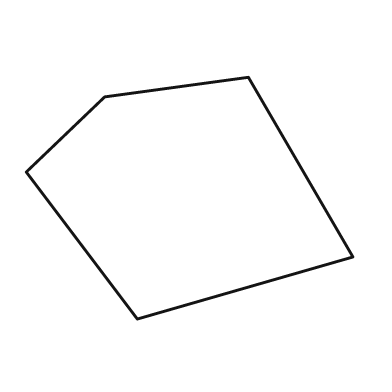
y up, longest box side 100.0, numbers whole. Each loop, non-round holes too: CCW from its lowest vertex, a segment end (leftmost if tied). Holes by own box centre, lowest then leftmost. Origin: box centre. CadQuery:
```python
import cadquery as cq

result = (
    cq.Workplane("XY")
    .moveTo(-16.0, -37.0)
    .lineTo(50.0, -18.0)
    .lineTo(18.0, 37.0)
    .lineTo(-26.0, 31.0)
    .lineTo(-50.0, 8.0)
    .close()
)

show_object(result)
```